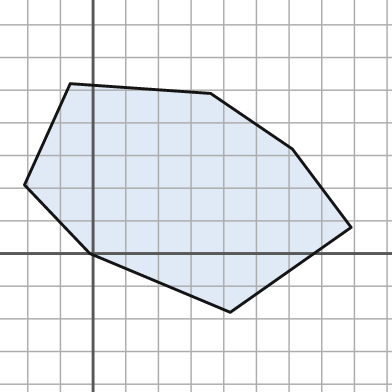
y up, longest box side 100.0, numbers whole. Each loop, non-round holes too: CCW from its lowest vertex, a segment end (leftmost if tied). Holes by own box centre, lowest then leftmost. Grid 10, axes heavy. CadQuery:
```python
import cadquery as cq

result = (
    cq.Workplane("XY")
    .moveTo(42.0, -18.0)
    .lineTo(79.0, 8.0)
    .lineTo(61.0, 32.0)
    .lineTo(36.0, 49.0)
    .lineTo(-7.0, 52.0)
    .lineTo(-21.0, 21.0)
    .lineTo(-1.0, 0.0)
    .close()
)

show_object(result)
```